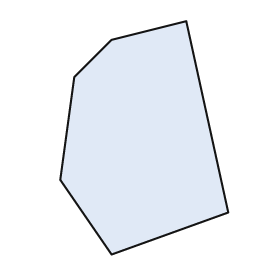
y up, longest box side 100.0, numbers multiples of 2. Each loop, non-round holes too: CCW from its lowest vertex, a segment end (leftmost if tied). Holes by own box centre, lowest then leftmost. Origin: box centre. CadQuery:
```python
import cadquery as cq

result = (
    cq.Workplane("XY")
    .moveTo(-14.0, -50.0)
    .lineTo(36.0, -32.0)
    .lineTo(18.0, 50.0)
    .lineTo(-14.0, 42.0)
    .lineTo(-30.0, 26.0)
    .lineTo(-36.0, -18.0)
    .close()
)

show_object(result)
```